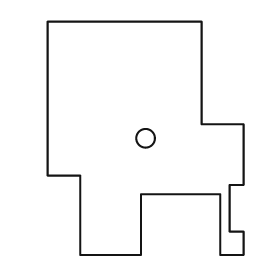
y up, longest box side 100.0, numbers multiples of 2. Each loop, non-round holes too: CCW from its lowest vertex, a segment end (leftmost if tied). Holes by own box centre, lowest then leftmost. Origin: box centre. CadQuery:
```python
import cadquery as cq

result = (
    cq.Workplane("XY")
    .moveTo(-28.0, -50.0)
    .lineTo(-2.0, -50.0)
    .lineTo(-2.0, -24.0)
    .lineTo(32.0, -24.0)
    .lineTo(32.0, -50.0)
    .lineTo(42.0, -50.0)
    .lineTo(42.0, -40.0)
    .lineTo(36.0, -40.0)
    .lineTo(36.0, -20.0)
    .lineTo(42.0, -20.0)
    .lineTo(42.0, 6.0)
    .lineTo(24.0, 6.0)
    .lineTo(24.0, 50.0)
    .lineTo(-42.0, 50.0)
    .lineTo(-42.0, -16.0)
    .lineTo(-28.0, -16.0)
    .close()
    .moveTo(0.0, 0.0)
    .circle(4.0)
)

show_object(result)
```